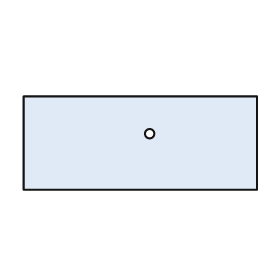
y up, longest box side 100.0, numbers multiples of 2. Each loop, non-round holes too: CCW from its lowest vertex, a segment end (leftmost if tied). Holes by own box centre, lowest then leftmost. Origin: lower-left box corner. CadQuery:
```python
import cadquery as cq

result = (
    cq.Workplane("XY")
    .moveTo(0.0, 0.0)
    .lineTo(100.0, 0.0)
    .lineTo(100.0, 40.0)
    .lineTo(0.0, 40.0)
    .close()
    .moveTo(54.0, 24.0)
    .circle(2.0)
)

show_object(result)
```